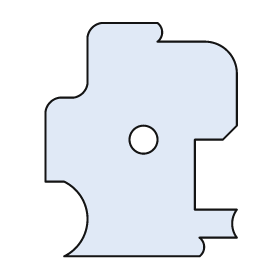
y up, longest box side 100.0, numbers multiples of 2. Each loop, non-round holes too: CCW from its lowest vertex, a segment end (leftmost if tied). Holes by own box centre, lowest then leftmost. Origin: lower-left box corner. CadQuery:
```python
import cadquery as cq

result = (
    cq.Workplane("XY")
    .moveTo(8.0, 0.0)
    .lineTo(66.0, 0.0)
    .threePointArc((68.0, 4.0), (66.0, 8.0))
    .lineTo(82.0, 8.0)
    .threePointArc((80.0, 14.0), (82.0, 20.0))
    .lineTo(64.0, 20.0)
    .lineTo(64.0, 50.0)
    .lineTo(76.0, 50.0)
    .lineTo(82.0, 56.0)
    .lineTo(82.0, 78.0)
    .threePointArc((78.0, 88.0), (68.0, 92.0))
    .lineTo(48.0, 92.0)
    .threePointArc((50.0, 96.0), (48.0, 100.0))
    .lineTo(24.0, 100.0)
    .threePointArc((20.0, 98.0), (18.0, 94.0))
    .lineTo(18.0, 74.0)
    .threePointArc((16.0, 70.0), (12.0, 68.0))
    .lineTo(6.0, 68.0)
    .threePointArc((2.0, 66.0), (0.0, 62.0))
    .lineTo(0.0, 32.0)
    .lineTo(8.0, 32.0)
    .threePointArc((18.0, 16.0), (8.0, 0.0))
    .close()
    .moveTo(42.0, 50.0)
    .circle(6.0)
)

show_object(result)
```